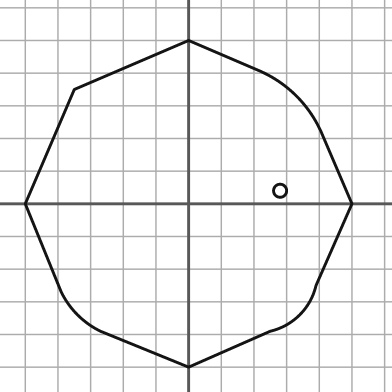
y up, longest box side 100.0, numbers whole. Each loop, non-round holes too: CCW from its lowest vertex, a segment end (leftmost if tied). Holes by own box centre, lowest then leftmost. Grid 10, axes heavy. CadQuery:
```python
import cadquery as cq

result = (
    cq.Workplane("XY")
    .moveTo(0.0, -50.0)
    .lineTo(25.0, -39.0)
    .threePointArc((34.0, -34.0), (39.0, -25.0))
    .lineTo(50.0, 0.0)
    .lineTo(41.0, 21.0)
    .threePointArc((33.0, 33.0), (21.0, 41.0))
    .lineTo(0.0, 50.0)
    .lineTo(-35.0, 35.0)
    .lineTo(-50.0, 0.0)
    .lineTo(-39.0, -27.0)
    .threePointArc((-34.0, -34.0), (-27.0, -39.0))
    .close()
    .moveTo(28.0, 4.0)
    .circle(2.0)
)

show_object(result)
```